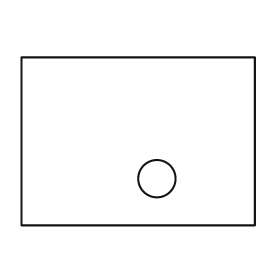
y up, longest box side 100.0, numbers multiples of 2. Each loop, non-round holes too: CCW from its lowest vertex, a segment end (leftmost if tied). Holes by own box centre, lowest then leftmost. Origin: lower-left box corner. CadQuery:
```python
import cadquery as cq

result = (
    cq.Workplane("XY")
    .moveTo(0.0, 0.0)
    .lineTo(100.0, 0.0)
    .lineTo(100.0, 72.0)
    .lineTo(0.0, 72.0)
    .close()
    .moveTo(58.0, 20.0)
    .circle(8.0)
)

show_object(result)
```